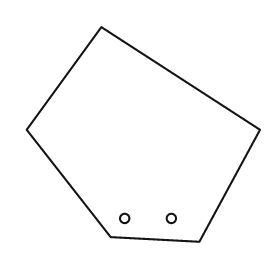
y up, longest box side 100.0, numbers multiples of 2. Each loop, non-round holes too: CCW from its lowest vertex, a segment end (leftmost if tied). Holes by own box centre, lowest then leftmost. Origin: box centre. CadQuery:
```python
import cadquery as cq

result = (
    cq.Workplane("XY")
    .moveTo(24.0, -46.0)
    .lineTo(50.0, 2.0)
    .lineTo(-18.0, 46.0)
    .lineTo(-50.0, 2.0)
    .lineTo(-14.0, -44.0)
    .close()
    .moveTo(-8.0, -36.0)
    .circle(2.0)
    .moveTo(12.0, -36.0)
    .circle(2.0)
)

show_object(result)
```